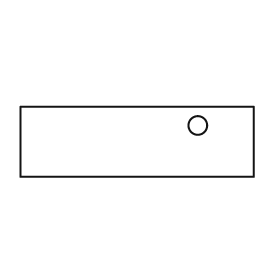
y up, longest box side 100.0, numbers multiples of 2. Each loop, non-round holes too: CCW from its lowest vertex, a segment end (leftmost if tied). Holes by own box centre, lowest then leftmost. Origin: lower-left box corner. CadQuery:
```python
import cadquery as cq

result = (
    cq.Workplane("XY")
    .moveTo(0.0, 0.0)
    .lineTo(100.0, 0.0)
    .lineTo(100.0, 30.0)
    .lineTo(0.0, 30.0)
    .close()
    .moveTo(76.0, 22.0)
    .circle(4.0)
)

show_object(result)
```